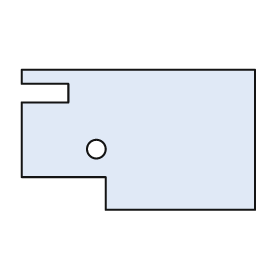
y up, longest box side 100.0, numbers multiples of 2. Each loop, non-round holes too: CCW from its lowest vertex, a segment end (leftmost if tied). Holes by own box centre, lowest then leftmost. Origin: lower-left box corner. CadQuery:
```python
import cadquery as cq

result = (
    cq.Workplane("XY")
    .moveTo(36.0, 0.0)
    .lineTo(100.0, 0.0)
    .lineTo(100.0, 60.0)
    .lineTo(0.0, 60.0)
    .lineTo(0.0, 54.0)
    .lineTo(20.0, 54.0)
    .lineTo(20.0, 46.0)
    .lineTo(0.0, 46.0)
    .lineTo(0.0, 14.0)
    .lineTo(36.0, 14.0)
    .close()
    .moveTo(32.0, 26.0)
    .circle(4.0)
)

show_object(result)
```